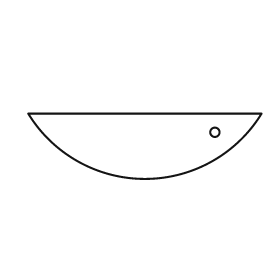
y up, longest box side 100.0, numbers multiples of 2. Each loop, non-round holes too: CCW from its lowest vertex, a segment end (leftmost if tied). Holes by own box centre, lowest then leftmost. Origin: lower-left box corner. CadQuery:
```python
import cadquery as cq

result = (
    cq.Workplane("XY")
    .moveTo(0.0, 28.0)
    .threePointArc((50.0, 0.0), (100.0, 28.0))
    .close()
    .moveTo(80.0, 20.0)
    .circle(2.0)
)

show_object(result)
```